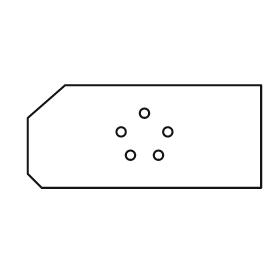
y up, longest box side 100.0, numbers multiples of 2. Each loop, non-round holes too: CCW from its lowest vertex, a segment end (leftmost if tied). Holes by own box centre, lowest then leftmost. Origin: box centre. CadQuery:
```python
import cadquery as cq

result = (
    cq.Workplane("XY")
    .moveTo(-44.0, -22.0)
    .lineTo(50.0, -22.0)
    .lineTo(50.0, 22.0)
    .lineTo(-34.0, 22.0)
    .lineTo(-50.0, 8.0)
    .lineTo(-50.0, -16.0)
    .close()
    .moveTo(-6.0, -8.0)
    .circle(2.0)
    .moveTo(6.0, -8.0)
    .circle(2.0)
    .moveTo(-10.0, 2.0)
    .circle(2.0)
    .moveTo(10.0, 2.0)
    .circle(2.0)
    .moveTo(0.0, 10.0)
    .circle(2.0)
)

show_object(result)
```